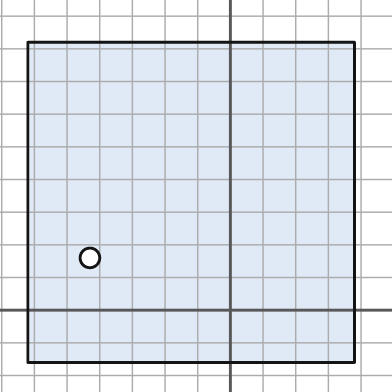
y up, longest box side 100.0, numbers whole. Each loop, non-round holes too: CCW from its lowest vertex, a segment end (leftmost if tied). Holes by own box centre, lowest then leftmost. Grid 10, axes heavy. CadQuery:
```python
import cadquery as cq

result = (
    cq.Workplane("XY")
    .moveTo(-62.0, -16.0)
    .lineTo(38.0, -16.0)
    .lineTo(38.0, 82.0)
    .lineTo(-62.0, 82.0)
    .close()
    .moveTo(-43.0, 16.0)
    .circle(3.0)
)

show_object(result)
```